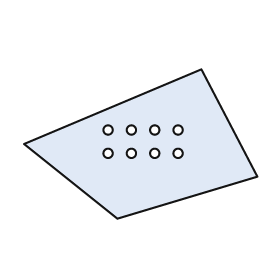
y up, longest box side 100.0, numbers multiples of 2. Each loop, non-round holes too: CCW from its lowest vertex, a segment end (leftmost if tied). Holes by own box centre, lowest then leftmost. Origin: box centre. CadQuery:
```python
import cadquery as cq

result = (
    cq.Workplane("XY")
    .moveTo(-10.0, -32.0)
    .lineTo(50.0, -14.0)
    .lineTo(26.0, 32.0)
    .lineTo(-50.0, 0.0)
    .close()
    .moveTo(-14.0, -4.0)
    .circle(2.0)
    .moveTo(-4.0, -4.0)
    .circle(2.0)
    .moveTo(6.0, -4.0)
    .circle(2.0)
    .moveTo(16.0, -4.0)
    .circle(2.0)
    .moveTo(-14.0, 6.0)
    .circle(2.0)
    .moveTo(-4.0, 6.0)
    .circle(2.0)
    .moveTo(6.0, 6.0)
    .circle(2.0)
    .moveTo(16.0, 6.0)
    .circle(2.0)
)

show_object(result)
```